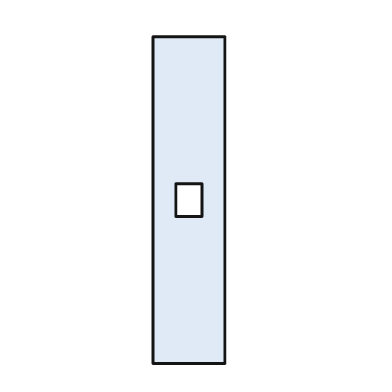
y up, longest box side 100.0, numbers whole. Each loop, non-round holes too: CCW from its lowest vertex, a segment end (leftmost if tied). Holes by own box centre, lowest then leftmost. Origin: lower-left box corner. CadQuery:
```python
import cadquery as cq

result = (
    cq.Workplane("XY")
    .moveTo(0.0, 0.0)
    .lineTo(22.0, 0.0)
    .lineTo(22.0, 100.0)
    .lineTo(0.0, 100.0)
    .close()
    .moveTo(7.0, 45.0)
    .lineTo(15.0, 45.0)
    .lineTo(15.0, 55.0)
    .lineTo(7.0, 55.0)
    .close()
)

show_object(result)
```